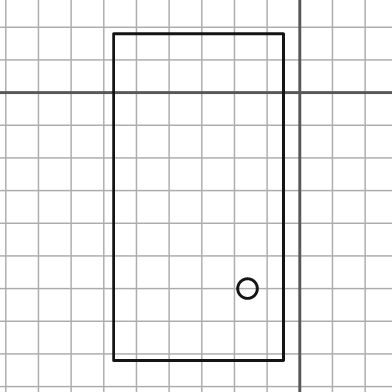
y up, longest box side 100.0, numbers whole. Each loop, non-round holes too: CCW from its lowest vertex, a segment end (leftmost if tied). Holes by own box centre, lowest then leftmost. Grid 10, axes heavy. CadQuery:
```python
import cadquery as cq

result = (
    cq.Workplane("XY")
    .moveTo(-57.0, -82.0)
    .lineTo(-5.0, -82.0)
    .lineTo(-5.0, 18.0)
    .lineTo(-57.0, 18.0)
    .close()
    .moveTo(-16.0, -60.0)
    .circle(3.0)
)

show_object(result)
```